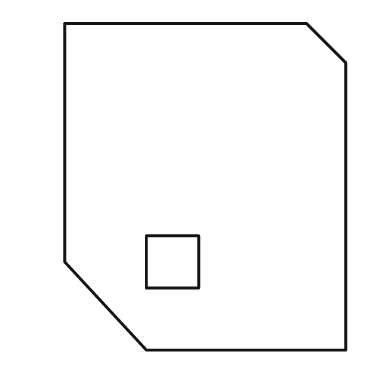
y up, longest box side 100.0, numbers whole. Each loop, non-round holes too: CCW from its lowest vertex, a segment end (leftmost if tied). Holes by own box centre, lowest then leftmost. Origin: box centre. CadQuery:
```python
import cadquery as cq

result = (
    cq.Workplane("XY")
    .moveTo(-18.0, -50.0)
    .lineTo(43.0, -50.0)
    .lineTo(43.0, 38.0)
    .lineTo(31.0, 50.0)
    .lineTo(-43.0, 50.0)
    .lineTo(-43.0, -23.0)
    .close()
    .moveTo(-18.0, -31.0)
    .lineTo(-2.0, -31.0)
    .lineTo(-2.0, -15.0)
    .lineTo(-18.0, -15.0)
    .close()
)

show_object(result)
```